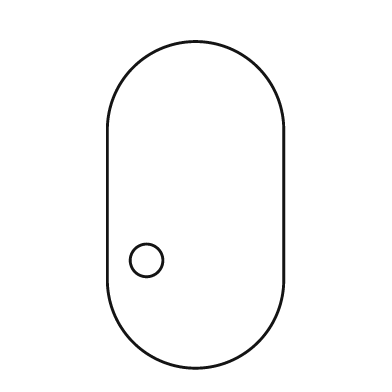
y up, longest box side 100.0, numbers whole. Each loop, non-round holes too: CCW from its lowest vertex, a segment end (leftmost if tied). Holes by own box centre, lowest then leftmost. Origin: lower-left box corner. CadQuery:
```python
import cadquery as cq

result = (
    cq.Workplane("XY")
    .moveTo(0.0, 27.0)
    .threePointArc((27.0, 0.0), (54.0, 27.0))
    .lineTo(54.0, 73.0)
    .threePointArc((27.0, 100.0), (0.0, 73.0))
    .close()
    .moveTo(12.0, 33.0)
    .circle(5.0)
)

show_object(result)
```